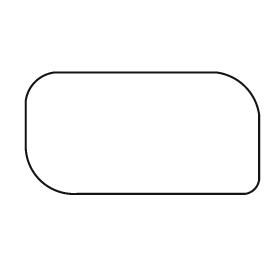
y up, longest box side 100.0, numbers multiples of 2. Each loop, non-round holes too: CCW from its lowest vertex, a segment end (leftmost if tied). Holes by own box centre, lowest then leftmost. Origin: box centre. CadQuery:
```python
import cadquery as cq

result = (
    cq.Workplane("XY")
    .moveTo(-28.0, -26.0)
    .lineTo(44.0, -26.0)
    .threePointArc((48.0, -24.0), (50.0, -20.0))
    .lineTo(50.0, 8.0)
    .threePointArc((44.0, 20.0), (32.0, 26.0))
    .lineTo(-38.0, 26.0)
    .threePointArc((-46.0, 22.0), (-50.0, 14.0))
    .lineTo(-50.0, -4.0)
    .threePointArc((-44.0, -20.0), (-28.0, -26.0))
    .close()
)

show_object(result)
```